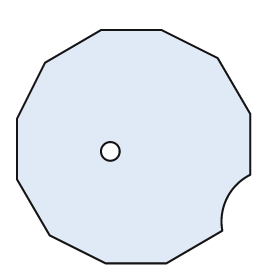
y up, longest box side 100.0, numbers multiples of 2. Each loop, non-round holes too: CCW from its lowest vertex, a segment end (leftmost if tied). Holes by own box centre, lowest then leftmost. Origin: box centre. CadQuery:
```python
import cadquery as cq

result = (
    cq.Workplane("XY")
    .moveTo(-12.0, -50.0)
    .lineTo(14.0, -50.0)
    .lineTo(38.0, -36.0)
    .threePointArc((40.0, -22.0), (50.0, -12.0))
    .lineTo(50.0, 14.0)
    .lineTo(36.0, 38.0)
    .lineTo(12.0, 50.0)
    .lineTo(-14.0, 50.0)
    .lineTo(-38.0, 36.0)
    .lineTo(-50.0, 12.0)
    .lineTo(-50.0, -14.0)
    .lineTo(-36.0, -38.0)
    .close()
    .moveTo(-10.0, -2.0)
    .circle(4.0)
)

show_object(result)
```